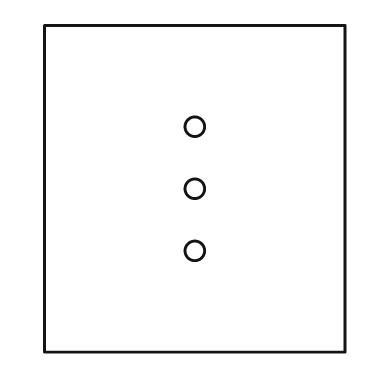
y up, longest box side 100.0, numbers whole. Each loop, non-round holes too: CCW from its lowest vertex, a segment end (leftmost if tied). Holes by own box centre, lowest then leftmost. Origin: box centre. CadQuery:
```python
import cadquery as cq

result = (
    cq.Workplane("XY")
    .moveTo(-46.0, -50.0)
    .lineTo(46.0, -50.0)
    .lineTo(46.0, 50.0)
    .lineTo(-46.0, 50.0)
    .close()
    .moveTo(0.0, -19.0)
    .circle(3.0)
    .moveTo(0.0, 0.0)
    .circle(3.0)
    .moveTo(0.0, 19.0)
    .circle(3.0)
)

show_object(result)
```